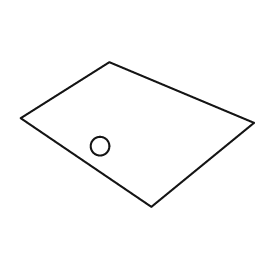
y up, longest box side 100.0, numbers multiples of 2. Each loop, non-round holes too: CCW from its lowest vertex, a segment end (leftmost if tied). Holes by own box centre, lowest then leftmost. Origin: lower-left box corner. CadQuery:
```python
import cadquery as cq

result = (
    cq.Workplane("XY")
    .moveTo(56.0, 0.0)
    .lineTo(100.0, 36.0)
    .lineTo(38.0, 62.0)
    .lineTo(0.0, 38.0)
    .close()
    .moveTo(34.0, 26.0)
    .circle(4.0)
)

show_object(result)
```